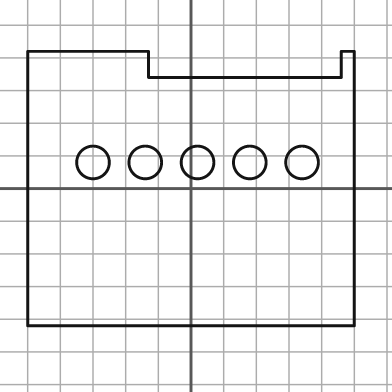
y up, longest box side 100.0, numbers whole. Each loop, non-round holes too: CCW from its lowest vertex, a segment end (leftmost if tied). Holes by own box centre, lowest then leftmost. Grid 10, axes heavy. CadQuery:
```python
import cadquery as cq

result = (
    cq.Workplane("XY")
    .moveTo(-50.0, -42.0)
    .lineTo(50.0, -42.0)
    .lineTo(50.0, 42.0)
    .lineTo(46.0, 42.0)
    .lineTo(46.0, 34.0)
    .lineTo(-13.0, 34.0)
    .lineTo(-13.0, 42.0)
    .lineTo(-50.0, 42.0)
    .close()
    .moveTo(-30.0, 8.0)
    .circle(5.0)
    .moveTo(-14.0, 8.0)
    .circle(5.0)
    .moveTo(2.0, 8.0)
    .circle(5.0)
    .moveTo(18.0, 8.0)
    .circle(5.0)
    .moveTo(34.0, 8.0)
    .circle(5.0)
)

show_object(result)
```